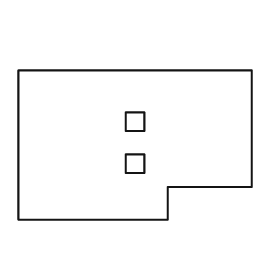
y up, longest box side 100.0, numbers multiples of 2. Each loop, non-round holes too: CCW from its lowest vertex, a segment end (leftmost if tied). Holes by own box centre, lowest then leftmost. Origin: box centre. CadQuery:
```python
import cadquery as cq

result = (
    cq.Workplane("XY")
    .moveTo(-50.0, -32.0)
    .lineTo(14.0, -32.0)
    .lineTo(14.0, -18.0)
    .lineTo(50.0, -18.0)
    .lineTo(50.0, 32.0)
    .lineTo(-50.0, 32.0)
    .close()
    .moveTo(-4.0, -12.0)
    .lineTo(4.0, -12.0)
    .lineTo(4.0, -4.0)
    .lineTo(-4.0, -4.0)
    .close()
    .moveTo(-4.0, 6.0)
    .lineTo(4.0, 6.0)
    .lineTo(4.0, 14.0)
    .lineTo(-4.0, 14.0)
    .close()
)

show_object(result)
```